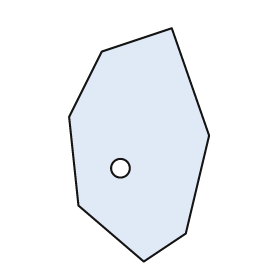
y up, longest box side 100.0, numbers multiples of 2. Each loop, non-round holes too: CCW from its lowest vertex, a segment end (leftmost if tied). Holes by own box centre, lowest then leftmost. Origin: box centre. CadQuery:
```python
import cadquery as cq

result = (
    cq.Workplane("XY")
    .moveTo(2.0, -50.0)
    .lineTo(20.0, -38.0)
    .lineTo(30.0, 4.0)
    .lineTo(14.0, 50.0)
    .lineTo(-16.0, 40.0)
    .lineTo(-30.0, 12.0)
    .lineTo(-26.0, -26.0)
    .close()
    .moveTo(-8.0, -10.0)
    .circle(4.0)
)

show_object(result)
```